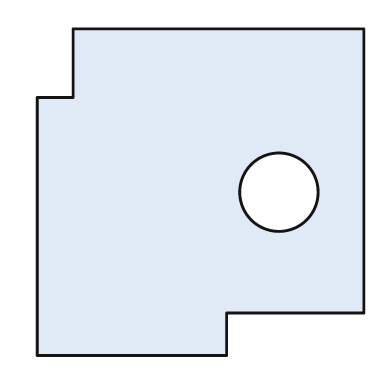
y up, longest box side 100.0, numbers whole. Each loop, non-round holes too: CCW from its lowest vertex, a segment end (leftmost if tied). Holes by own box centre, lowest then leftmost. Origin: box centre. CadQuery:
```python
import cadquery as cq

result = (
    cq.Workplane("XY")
    .moveTo(-50.0, -50.0)
    .lineTo(8.0, -50.0)
    .lineTo(8.0, -37.0)
    .lineTo(50.0, -37.0)
    .lineTo(50.0, 50.0)
    .lineTo(-39.0, 50.0)
    .lineTo(-39.0, 29.0)
    .lineTo(-50.0, 29.0)
    .close()
    .moveTo(24.0, 0.0)
    .circle(12.0)
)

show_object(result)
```